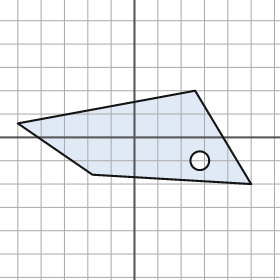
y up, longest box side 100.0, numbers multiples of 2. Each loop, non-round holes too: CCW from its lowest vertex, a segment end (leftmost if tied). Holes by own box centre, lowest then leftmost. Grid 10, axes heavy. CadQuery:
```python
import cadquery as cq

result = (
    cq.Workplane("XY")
    .moveTo(50.0, -20.0)
    .lineTo(26.0, 20.0)
    .lineTo(-50.0, 6.0)
    .lineTo(-18.0, -16.0)
    .close()
    .moveTo(28.0, -10.0)
    .circle(4.0)
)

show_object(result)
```